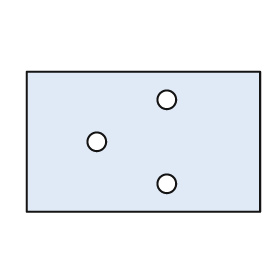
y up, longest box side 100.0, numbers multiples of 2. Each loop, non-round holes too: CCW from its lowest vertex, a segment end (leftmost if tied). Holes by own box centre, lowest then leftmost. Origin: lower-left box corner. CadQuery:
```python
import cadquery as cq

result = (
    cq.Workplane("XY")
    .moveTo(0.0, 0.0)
    .lineTo(100.0, 0.0)
    .lineTo(100.0, 60.0)
    .lineTo(0.0, 60.0)
    .close()
    .moveTo(60.0, 12.0)
    .circle(4.0)
    .moveTo(30.0, 30.0)
    .circle(4.0)
    .moveTo(60.0, 48.0)
    .circle(4.0)
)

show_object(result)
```